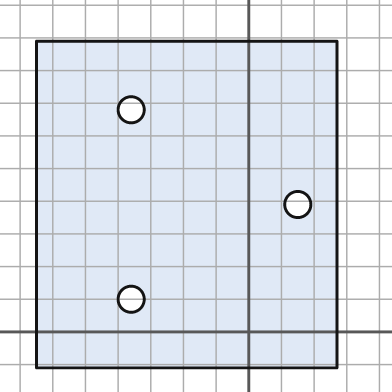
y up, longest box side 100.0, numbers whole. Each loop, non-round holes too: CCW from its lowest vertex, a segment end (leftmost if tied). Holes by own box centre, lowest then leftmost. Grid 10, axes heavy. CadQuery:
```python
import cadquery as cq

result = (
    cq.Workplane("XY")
    .moveTo(-65.0, -11.0)
    .lineTo(27.0, -11.0)
    .lineTo(27.0, 89.0)
    .lineTo(-65.0, 89.0)
    .close()
    .moveTo(-36.0, 10.0)
    .circle(4.0)
    .moveTo(15.0, 39.0)
    .circle(4.0)
    .moveTo(-36.0, 68.0)
    .circle(4.0)
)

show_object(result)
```